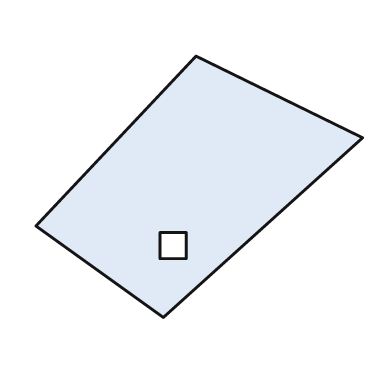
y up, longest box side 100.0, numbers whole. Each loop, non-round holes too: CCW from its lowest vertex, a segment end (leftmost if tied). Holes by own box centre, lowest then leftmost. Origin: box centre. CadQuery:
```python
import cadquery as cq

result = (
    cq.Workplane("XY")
    .moveTo(-11.0, -40.0)
    .lineTo(50.0, 15.0)
    .lineTo(-1.0, 40.0)
    .lineTo(-50.0, -12.0)
    .close()
    .moveTo(-12.0, -22.0)
    .lineTo(-4.0, -22.0)
    .lineTo(-4.0, -14.0)
    .lineTo(-12.0, -14.0)
    .close()
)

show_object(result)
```